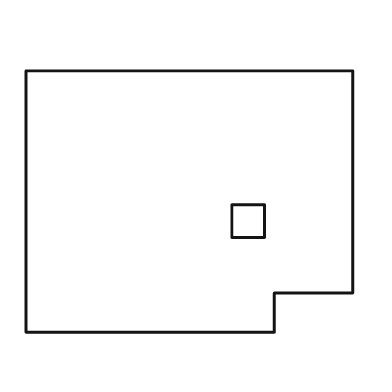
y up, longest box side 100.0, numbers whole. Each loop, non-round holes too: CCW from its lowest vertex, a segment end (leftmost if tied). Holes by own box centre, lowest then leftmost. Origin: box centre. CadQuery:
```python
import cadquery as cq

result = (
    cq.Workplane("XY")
    .moveTo(-50.0, -40.0)
    .lineTo(26.0, -40.0)
    .lineTo(26.0, -28.0)
    .lineTo(50.0, -28.0)
    .lineTo(50.0, 40.0)
    .lineTo(-50.0, 40.0)
    .close()
    .moveTo(13.0, -11.0)
    .lineTo(23.0, -11.0)
    .lineTo(23.0, -1.0)
    .lineTo(13.0, -1.0)
    .close()
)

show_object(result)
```